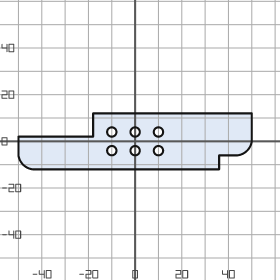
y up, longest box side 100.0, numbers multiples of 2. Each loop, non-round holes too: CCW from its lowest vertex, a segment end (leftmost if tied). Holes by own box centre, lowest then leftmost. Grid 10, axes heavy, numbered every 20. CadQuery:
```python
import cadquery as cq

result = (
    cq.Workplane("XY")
    .moveTo(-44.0, -12.0)
    .lineTo(36.0, -12.0)
    .lineTo(36.0, -6.0)
    .lineTo(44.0, -6.0)
    .threePointArc((48.0, -4.0), (50.0, 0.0))
    .lineTo(50.0, 12.0)
    .lineTo(-18.0, 12.0)
    .lineTo(-18.0, 2.0)
    .lineTo(-50.0, 2.0)
    .lineTo(-50.0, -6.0)
    .threePointArc((-48.0, -10.0), (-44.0, -12.0))
    .close()
    .moveTo(-10.0, -4.0)
    .circle(2.0)
    .moveTo(0.0, -4.0)
    .circle(2.0)
    .moveTo(10.0, -4.0)
    .circle(2.0)
    .moveTo(-10.0, 4.0)
    .circle(2.0)
    .moveTo(0.0, 4.0)
    .circle(2.0)
    .moveTo(10.0, 4.0)
    .circle(2.0)
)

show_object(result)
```